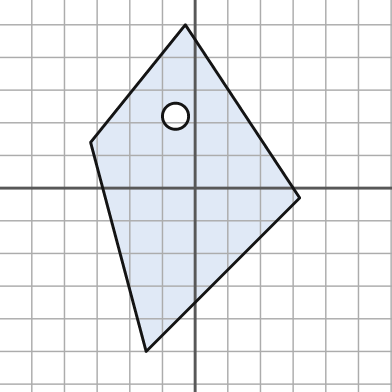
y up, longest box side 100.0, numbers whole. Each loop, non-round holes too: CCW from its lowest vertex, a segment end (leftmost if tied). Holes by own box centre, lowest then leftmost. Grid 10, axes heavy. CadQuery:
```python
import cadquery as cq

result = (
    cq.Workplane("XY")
    .moveTo(-15.0, -50.0)
    .lineTo(32.0, -3.0)
    .lineTo(-3.0, 50.0)
    .lineTo(-32.0, 14.0)
    .close()
    .moveTo(-6.0, 22.0)
    .circle(4.0)
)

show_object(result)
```